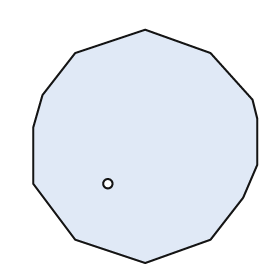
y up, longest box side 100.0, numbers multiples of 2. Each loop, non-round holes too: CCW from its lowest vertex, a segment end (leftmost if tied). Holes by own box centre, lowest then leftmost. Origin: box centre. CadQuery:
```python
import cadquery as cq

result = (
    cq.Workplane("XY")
    .moveTo(0.0, -50.0)
    .lineTo(28.0, -40.0)
    .lineTo(42.0, -22.0)
    .lineTo(48.0, -8.0)
    .lineTo(48.0, 12.0)
    .lineTo(46.0, 20.0)
    .lineTo(28.0, 40.0)
    .lineTo(0.0, 50.0)
    .lineTo(-30.0, 40.0)
    .lineTo(-44.0, 22.0)
    .lineTo(-48.0, 8.0)
    .lineTo(-48.0, -16.0)
    .lineTo(-30.0, -40.0)
    .close()
    .moveTo(-16.0, -16.0)
    .circle(2.0)
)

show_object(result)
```